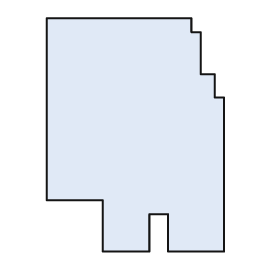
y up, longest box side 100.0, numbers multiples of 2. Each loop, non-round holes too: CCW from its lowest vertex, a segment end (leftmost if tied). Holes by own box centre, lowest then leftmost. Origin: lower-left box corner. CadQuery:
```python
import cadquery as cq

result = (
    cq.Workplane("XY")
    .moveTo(24.0, 0.0)
    .lineTo(44.0, 0.0)
    .lineTo(44.0, 16.0)
    .lineTo(52.0, 16.0)
    .lineTo(52.0, 0.0)
    .lineTo(76.0, 0.0)
    .lineTo(76.0, 66.0)
    .lineTo(72.0, 66.0)
    .lineTo(72.0, 76.0)
    .lineTo(66.0, 76.0)
    .lineTo(66.0, 94.0)
    .lineTo(62.0, 94.0)
    .lineTo(62.0, 100.0)
    .lineTo(0.0, 100.0)
    .lineTo(0.0, 22.0)
    .lineTo(24.0, 22.0)
    .close()
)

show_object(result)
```